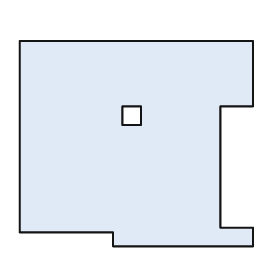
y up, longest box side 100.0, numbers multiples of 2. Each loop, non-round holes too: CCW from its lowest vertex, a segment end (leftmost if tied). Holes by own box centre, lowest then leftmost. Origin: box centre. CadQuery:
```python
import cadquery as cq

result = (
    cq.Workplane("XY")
    .moveTo(-10.0, -44.0)
    .lineTo(50.0, -44.0)
    .lineTo(50.0, -36.0)
    .lineTo(36.0, -36.0)
    .lineTo(36.0, 16.0)
    .lineTo(50.0, 16.0)
    .lineTo(50.0, 44.0)
    .lineTo(-50.0, 44.0)
    .lineTo(-50.0, -38.0)
    .lineTo(-10.0, -38.0)
    .close()
    .moveTo(-6.0, 8.0)
    .lineTo(2.0, 8.0)
    .lineTo(2.0, 16.0)
    .lineTo(-6.0, 16.0)
    .close()
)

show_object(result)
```